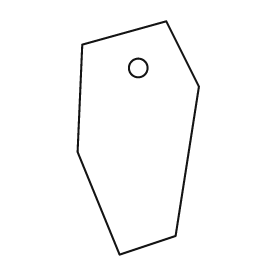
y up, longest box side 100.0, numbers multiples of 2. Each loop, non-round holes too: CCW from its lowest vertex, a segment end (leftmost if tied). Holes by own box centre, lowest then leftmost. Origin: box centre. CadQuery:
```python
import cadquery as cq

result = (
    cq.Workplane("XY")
    .moveTo(-8.0, -50.0)
    .lineTo(16.0, -42.0)
    .lineTo(26.0, 22.0)
    .lineTo(12.0, 50.0)
    .lineTo(-24.0, 40.0)
    .lineTo(-26.0, -6.0)
    .close()
    .moveTo(0.0, 30.0)
    .circle(4.0)
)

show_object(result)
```